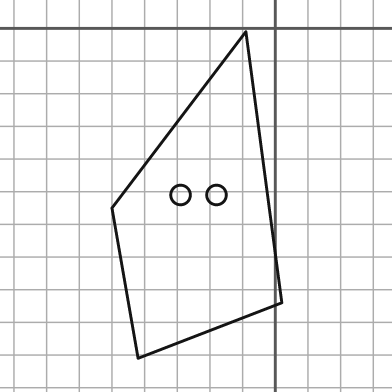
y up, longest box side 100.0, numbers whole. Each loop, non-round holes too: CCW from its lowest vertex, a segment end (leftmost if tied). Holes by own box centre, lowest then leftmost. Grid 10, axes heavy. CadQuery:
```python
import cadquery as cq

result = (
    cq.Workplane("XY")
    .moveTo(-42.0, -101.0)
    .lineTo(2.0, -84.0)
    .lineTo(-9.0, -1.0)
    .lineTo(-50.0, -55.0)
    .close()
    .moveTo(-29.0, -51.0)
    .circle(3.0)
    .moveTo(-18.0, -51.0)
    .circle(3.0)
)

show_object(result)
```